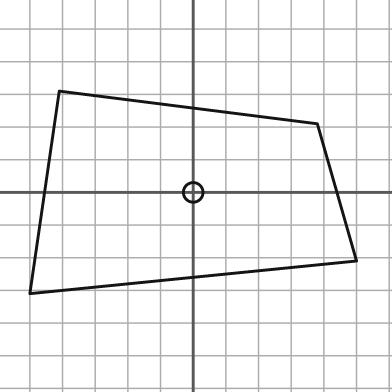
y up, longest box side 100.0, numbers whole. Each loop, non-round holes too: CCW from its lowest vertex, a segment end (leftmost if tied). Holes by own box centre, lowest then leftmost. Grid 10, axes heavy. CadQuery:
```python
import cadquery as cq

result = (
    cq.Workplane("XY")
    .moveTo(-50.0, -31.0)
    .lineTo(50.0, -21.0)
    .lineTo(38.0, 21.0)
    .lineTo(-41.0, 31.0)
    .close()
    .moveTo(0.0, 0.0)
    .circle(3.0)
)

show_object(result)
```